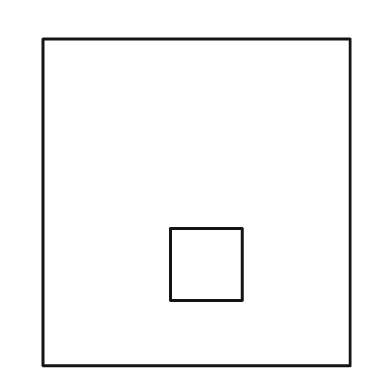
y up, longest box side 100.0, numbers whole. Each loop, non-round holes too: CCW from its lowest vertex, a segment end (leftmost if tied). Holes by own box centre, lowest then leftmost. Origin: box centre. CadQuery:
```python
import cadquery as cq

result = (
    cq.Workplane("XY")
    .moveTo(-47.0, -50.0)
    .lineTo(47.0, -50.0)
    .lineTo(47.0, 50.0)
    .lineTo(-47.0, 50.0)
    .close()
    .moveTo(-8.0, -30.0)
    .lineTo(14.0, -30.0)
    .lineTo(14.0, -8.0)
    .lineTo(-8.0, -8.0)
    .close()
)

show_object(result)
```